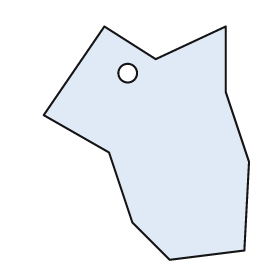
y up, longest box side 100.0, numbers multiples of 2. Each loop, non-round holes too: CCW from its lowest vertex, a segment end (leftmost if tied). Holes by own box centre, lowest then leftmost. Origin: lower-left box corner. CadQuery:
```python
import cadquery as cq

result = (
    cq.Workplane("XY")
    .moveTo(54.0, 0.0)
    .lineTo(86.0, 4.0)
    .lineTo(88.0, 42.0)
    .lineTo(78.0, 72.0)
    .lineTo(78.0, 100.0)
    .lineTo(48.0, 86.0)
    .lineTo(26.0, 100.0)
    .lineTo(0.0, 62.0)
    .lineTo(28.0, 46.0)
    .lineTo(38.0, 16.0)
    .close()
    .moveTo(36.0, 80.0)
    .circle(4.0)
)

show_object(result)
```